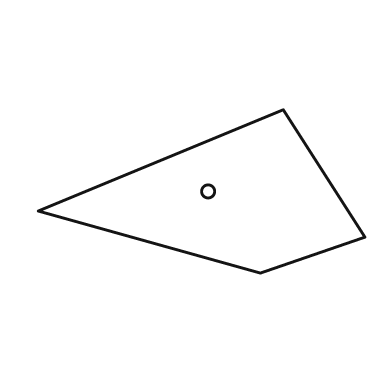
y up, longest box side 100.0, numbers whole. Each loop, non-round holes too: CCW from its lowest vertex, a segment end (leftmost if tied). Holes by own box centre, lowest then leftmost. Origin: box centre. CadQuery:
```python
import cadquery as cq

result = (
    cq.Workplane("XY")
    .moveTo(18.0, -25.0)
    .lineTo(50.0, -14.0)
    .lineTo(25.0, 25.0)
    .lineTo(-50.0, -6.0)
    .close()
    .moveTo(2.0, 0.0)
    .circle(2.0)
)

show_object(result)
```